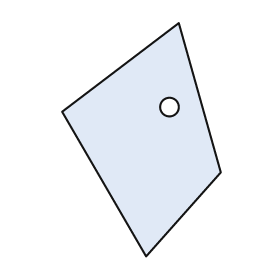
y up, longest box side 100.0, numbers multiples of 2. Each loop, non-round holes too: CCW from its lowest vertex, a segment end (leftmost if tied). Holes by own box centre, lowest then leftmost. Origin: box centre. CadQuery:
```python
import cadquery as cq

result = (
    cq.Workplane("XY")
    .moveTo(2.0, -50.0)
    .lineTo(34.0, -14.0)
    .lineTo(16.0, 50.0)
    .lineTo(-34.0, 12.0)
    .close()
    .moveTo(12.0, 14.0)
    .circle(4.0)
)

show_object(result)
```